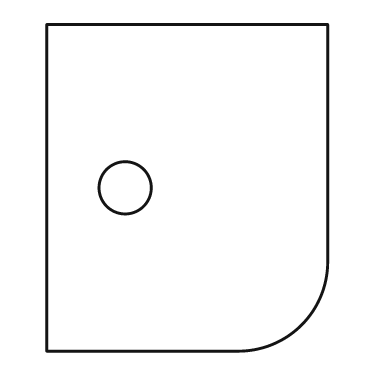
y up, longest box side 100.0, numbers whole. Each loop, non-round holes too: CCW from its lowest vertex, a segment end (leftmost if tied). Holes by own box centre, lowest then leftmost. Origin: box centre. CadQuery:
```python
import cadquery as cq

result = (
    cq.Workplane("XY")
    .moveTo(-43.0, -50.0)
    .lineTo(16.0, -50.0)
    .threePointArc((35.0, -42.0), (43.0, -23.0))
    .lineTo(43.0, 50.0)
    .lineTo(-43.0, 50.0)
    .close()
    .moveTo(-19.0, 0.0)
    .circle(8.0)
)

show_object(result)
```